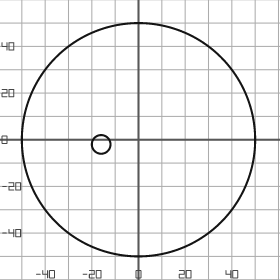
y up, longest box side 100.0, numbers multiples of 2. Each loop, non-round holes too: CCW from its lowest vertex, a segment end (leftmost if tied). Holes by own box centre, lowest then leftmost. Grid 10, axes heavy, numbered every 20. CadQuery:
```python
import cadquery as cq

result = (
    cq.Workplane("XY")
    .moveTo(0.0, 0.0)
    .circle(50.0)
    .moveTo(-16.0, -2.0)
    .circle(4.0)
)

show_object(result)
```